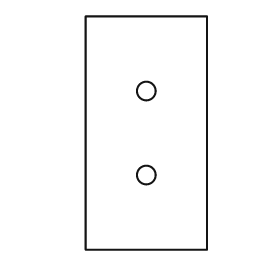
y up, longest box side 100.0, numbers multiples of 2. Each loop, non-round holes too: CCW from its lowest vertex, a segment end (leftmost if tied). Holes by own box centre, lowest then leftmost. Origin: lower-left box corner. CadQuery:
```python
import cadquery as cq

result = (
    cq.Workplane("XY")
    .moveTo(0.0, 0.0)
    .lineTo(52.0, 0.0)
    .lineTo(52.0, 100.0)
    .lineTo(0.0, 100.0)
    .close()
    .moveTo(26.0, 32.0)
    .circle(4.0)
    .moveTo(26.0, 68.0)
    .circle(4.0)
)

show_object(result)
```